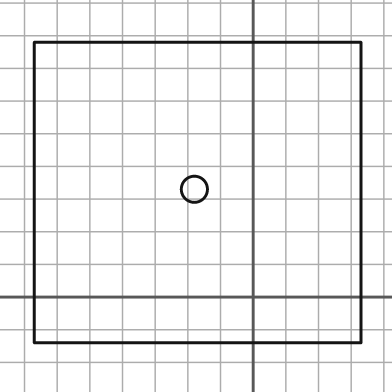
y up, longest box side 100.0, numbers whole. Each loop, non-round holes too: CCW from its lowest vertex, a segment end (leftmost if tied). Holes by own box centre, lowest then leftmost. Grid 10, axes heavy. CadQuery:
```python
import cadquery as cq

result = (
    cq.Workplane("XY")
    .moveTo(-67.0, -14.0)
    .lineTo(33.0, -14.0)
    .lineTo(33.0, 78.0)
    .lineTo(-67.0, 78.0)
    .close()
    .moveTo(-18.0, 33.0)
    .circle(4.0)
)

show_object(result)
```